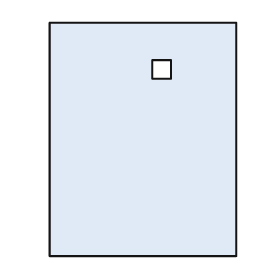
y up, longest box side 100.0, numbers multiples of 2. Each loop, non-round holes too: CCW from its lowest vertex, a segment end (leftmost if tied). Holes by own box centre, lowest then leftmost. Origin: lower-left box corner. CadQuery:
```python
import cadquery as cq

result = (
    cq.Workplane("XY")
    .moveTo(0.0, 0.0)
    .lineTo(80.0, 0.0)
    .lineTo(80.0, 100.0)
    .lineTo(0.0, 100.0)
    .close()
    .moveTo(44.0, 76.0)
    .lineTo(52.0, 76.0)
    .lineTo(52.0, 84.0)
    .lineTo(44.0, 84.0)
    .close()
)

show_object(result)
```